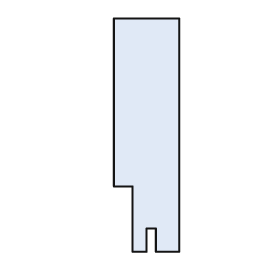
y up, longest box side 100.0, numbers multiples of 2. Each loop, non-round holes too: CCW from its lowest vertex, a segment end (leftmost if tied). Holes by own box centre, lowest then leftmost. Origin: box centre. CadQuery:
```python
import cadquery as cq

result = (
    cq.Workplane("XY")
    .moveTo(-6.0, -50.0)
    .lineTo(0.0, -50.0)
    .lineTo(0.0, -40.0)
    .lineTo(4.0, -40.0)
    .lineTo(4.0, -50.0)
    .lineTo(14.0, -50.0)
    .lineTo(14.0, 50.0)
    .lineTo(-14.0, 50.0)
    .lineTo(-14.0, -22.0)
    .lineTo(-6.0, -22.0)
    .close()
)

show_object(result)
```